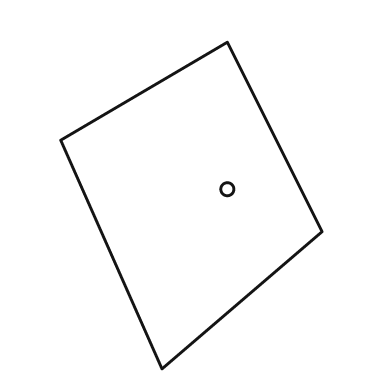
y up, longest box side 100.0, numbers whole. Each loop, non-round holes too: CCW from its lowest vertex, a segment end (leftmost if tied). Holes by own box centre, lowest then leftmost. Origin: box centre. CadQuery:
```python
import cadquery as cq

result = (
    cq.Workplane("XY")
    .moveTo(-9.0, -50.0)
    .lineTo(40.0, -8.0)
    .lineTo(11.0, 50.0)
    .lineTo(-40.0, 20.0)
    .close()
    .moveTo(11.0, 5.0)
    .circle(2.0)
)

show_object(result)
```